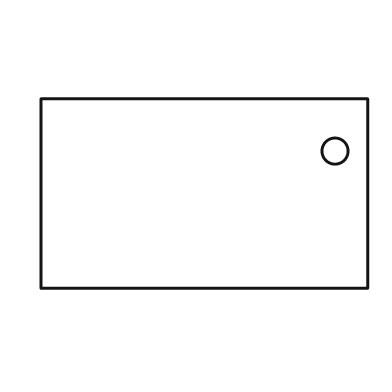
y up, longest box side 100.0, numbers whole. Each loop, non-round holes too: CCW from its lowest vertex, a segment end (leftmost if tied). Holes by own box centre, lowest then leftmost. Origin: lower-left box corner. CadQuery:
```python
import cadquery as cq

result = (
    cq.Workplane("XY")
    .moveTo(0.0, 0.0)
    .lineTo(100.0, 0.0)
    .lineTo(100.0, 58.0)
    .lineTo(0.0, 58.0)
    .close()
    .moveTo(90.0, 42.0)
    .circle(4.0)
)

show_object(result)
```